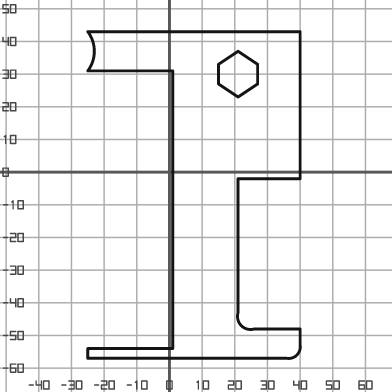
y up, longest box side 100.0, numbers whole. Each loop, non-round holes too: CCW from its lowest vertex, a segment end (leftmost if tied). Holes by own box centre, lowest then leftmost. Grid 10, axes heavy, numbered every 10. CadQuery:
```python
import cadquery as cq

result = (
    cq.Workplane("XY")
    .moveTo(-25.0, -57.0)
    .lineTo(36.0, -57.0)
    .threePointArc((39.0, -56.0), (40.0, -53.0))
    .lineTo(40.0, -48.0)
    .lineTo(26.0, -48.0)
    .threePointArc((22.0, -47.0), (21.0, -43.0))
    .lineTo(21.0, -2.0)
    .lineTo(40.0, -2.0)
    .lineTo(40.0, 43.0)
    .lineTo(-25.0, 43.0)
    .threePointArc((-23.0, 37.0), (-25.0, 31.0))
    .lineTo(1.0, 31.0)
    .lineTo(1.0, -54.0)
    .lineTo(-25.0, -54.0)
    .close()
    .moveTo(21.0, 23.0)
    .lineTo(27.0, 27.0)
    .lineTo(27.0, 33.0)
    .lineTo(21.0, 37.0)
    .lineTo(15.0, 33.0)
    .lineTo(15.0, 27.0)
    .close()
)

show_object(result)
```